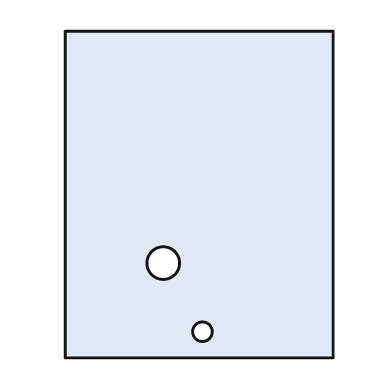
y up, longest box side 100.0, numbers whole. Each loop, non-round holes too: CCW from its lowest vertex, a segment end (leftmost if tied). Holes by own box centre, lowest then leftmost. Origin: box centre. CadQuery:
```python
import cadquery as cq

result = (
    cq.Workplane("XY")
    .moveTo(-41.0, -50.0)
    .lineTo(41.0, -50.0)
    .lineTo(41.0, 50.0)
    .lineTo(-41.0, 50.0)
    .close()
    .moveTo(1.0, -42.0)
    .circle(3.0)
    .moveTo(-11.0, -21.0)
    .circle(5.0)
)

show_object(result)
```